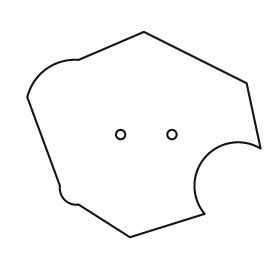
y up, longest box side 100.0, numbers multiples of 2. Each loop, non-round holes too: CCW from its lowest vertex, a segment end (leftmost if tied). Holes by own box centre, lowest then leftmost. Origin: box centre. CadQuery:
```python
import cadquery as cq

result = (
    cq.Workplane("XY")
    .moveTo(-6.0, -44.0)
    .lineTo(26.0, -34.0)
    .threePointArc((26.0, -10.0), (50.0, -6.0))
    .lineTo(44.0, 22.0)
    .lineTo(0.0, 44.0)
    .lineTo(-28.0, 32.0)
    .threePointArc((-42.0, 28.0), (-50.0, 16.0))
    .lineTo(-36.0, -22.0)
    .threePointArc((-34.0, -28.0), (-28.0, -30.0))
    .close()
    .moveTo(-10.0, 0.0)
    .circle(2.0)
    .moveTo(12.0, 0.0)
    .circle(2.0)
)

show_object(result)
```